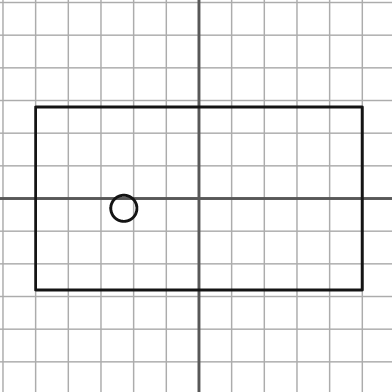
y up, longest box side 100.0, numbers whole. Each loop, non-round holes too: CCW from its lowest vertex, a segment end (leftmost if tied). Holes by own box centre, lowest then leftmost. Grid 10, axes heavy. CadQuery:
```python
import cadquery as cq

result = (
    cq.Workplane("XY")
    .moveTo(-50.0, -28.0)
    .lineTo(50.0, -28.0)
    .lineTo(50.0, 28.0)
    .lineTo(-50.0, 28.0)
    .close()
    .moveTo(-23.0, -3.0)
    .circle(4.0)
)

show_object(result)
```